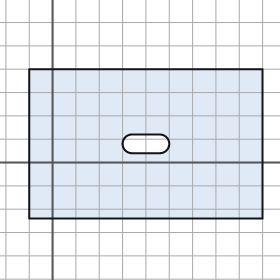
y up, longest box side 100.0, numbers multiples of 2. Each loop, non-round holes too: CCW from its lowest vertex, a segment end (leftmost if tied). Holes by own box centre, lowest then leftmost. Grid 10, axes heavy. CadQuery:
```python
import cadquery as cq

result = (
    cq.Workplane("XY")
    .moveTo(-10.0, -24.0)
    .lineTo(90.0, -24.0)
    .lineTo(90.0, 40.0)
    .lineTo(-10.0, 40.0)
    .close()
    .moveTo(34.0, 4.0)
    .lineTo(46.0, 4.0)
    .threePointArc((50.0, 8.0), (46.0, 12.0))
    .lineTo(34.0, 12.0)
    .threePointArc((30.0, 8.0), (34.0, 4.0))
    .close()
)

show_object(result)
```